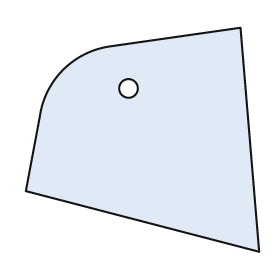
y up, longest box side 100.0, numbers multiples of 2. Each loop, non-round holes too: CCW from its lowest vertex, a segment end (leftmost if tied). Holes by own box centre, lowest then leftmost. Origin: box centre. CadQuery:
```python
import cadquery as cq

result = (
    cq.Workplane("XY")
    .moveTo(50.0, -48.0)
    .lineTo(42.0, 48.0)
    .lineTo(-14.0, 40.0)
    .threePointArc((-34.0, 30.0), (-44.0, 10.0))
    .lineTo(-50.0, -22.0)
    .close()
    .moveTo(-6.0, 22.0)
    .circle(4.0)
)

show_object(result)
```